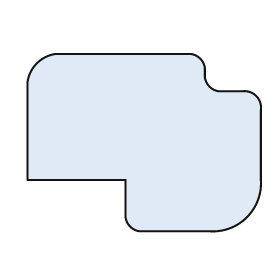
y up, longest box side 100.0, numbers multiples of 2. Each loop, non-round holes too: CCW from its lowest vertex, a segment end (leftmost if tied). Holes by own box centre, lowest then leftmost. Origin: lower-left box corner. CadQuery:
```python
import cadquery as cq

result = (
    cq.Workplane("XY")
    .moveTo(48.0, 0.0)
    .lineTo(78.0, 0.0)
    .threePointArc((94.0, 6.0), (100.0, 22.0))
    .lineTo(100.0, 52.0)
    .threePointArc((98.0, 58.0), (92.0, 60.0))
    .lineTo(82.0, 60.0)
    .threePointArc((78.0, 62.0), (76.0, 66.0))
    .lineTo(76.0, 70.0)
    .threePointArc((74.0, 74.0), (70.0, 76.0))
    .lineTo(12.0, 76.0)
    .threePointArc((4.0, 72.0), (0.0, 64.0))
    .lineTo(0.0, 22.0)
    .lineTo(42.0, 22.0)
    .lineTo(42.0, 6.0)
    .threePointArc((44.0, 2.0), (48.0, 0.0))
    .close()
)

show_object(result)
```